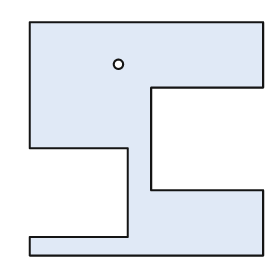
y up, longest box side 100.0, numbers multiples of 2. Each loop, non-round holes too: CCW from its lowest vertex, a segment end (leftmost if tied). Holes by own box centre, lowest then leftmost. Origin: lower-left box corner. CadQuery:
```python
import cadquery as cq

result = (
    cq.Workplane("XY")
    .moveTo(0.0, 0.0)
    .lineTo(100.0, 0.0)
    .lineTo(100.0, 28.0)
    .lineTo(52.0, 28.0)
    .lineTo(52.0, 72.0)
    .lineTo(100.0, 72.0)
    .lineTo(100.0, 100.0)
    .lineTo(0.0, 100.0)
    .lineTo(0.0, 46.0)
    .lineTo(42.0, 46.0)
    .lineTo(42.0, 8.0)
    .lineTo(0.0, 8.0)
    .close()
    .moveTo(38.0, 82.0)
    .circle(2.0)
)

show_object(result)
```